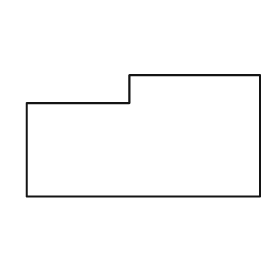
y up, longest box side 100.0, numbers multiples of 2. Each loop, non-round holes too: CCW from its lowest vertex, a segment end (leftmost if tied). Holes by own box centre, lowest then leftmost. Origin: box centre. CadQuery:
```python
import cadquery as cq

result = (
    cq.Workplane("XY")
    .moveTo(-50.0, -26.0)
    .lineTo(50.0, -26.0)
    .lineTo(50.0, 26.0)
    .lineTo(-6.0, 26.0)
    .lineTo(-6.0, 14.0)
    .lineTo(-50.0, 14.0)
    .close()
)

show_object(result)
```